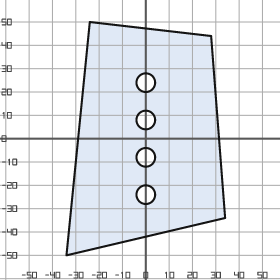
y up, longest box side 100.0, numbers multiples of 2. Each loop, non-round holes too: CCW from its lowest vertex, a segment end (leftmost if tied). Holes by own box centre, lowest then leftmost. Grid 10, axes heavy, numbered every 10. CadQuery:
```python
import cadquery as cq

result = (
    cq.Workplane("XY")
    .moveTo(-34.0, -50.0)
    .lineTo(34.0, -34.0)
    .lineTo(28.0, 44.0)
    .lineTo(-24.0, 50.0)
    .close()
    .moveTo(0.0, -24.0)
    .circle(4.0)
    .moveTo(0.0, -8.0)
    .circle(4.0)
    .moveTo(0.0, 8.0)
    .circle(4.0)
    .moveTo(0.0, 24.0)
    .circle(4.0)
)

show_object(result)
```